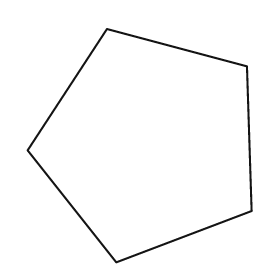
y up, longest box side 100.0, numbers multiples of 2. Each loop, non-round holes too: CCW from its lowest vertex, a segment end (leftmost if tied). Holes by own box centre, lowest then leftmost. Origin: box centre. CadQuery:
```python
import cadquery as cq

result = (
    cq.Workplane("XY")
    .moveTo(-10.0, -50.0)
    .lineTo(48.0, -28.0)
    .lineTo(46.0, 34.0)
    .lineTo(-14.0, 50.0)
    .lineTo(-48.0, -2.0)
    .close()
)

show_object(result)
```